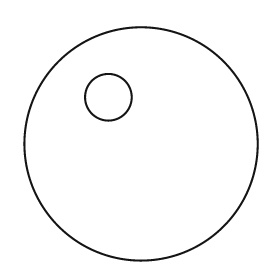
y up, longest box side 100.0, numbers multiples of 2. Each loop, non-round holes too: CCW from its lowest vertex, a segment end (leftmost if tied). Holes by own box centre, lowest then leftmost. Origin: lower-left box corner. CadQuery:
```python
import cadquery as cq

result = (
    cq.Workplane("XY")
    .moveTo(50.0, 50.0)
    .circle(50.0)
    .moveTo(36.0, 70.0)
    .circle(10.0)
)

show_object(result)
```